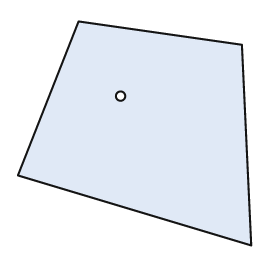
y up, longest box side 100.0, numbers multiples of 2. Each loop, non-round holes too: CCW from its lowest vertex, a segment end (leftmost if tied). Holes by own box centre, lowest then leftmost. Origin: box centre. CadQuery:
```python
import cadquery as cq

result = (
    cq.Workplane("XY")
    .moveTo(50.0, -48.0)
    .lineTo(46.0, 38.0)
    .lineTo(-24.0, 48.0)
    .lineTo(-50.0, -18.0)
    .close()
    .moveTo(-6.0, 16.0)
    .circle(2.0)
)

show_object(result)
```